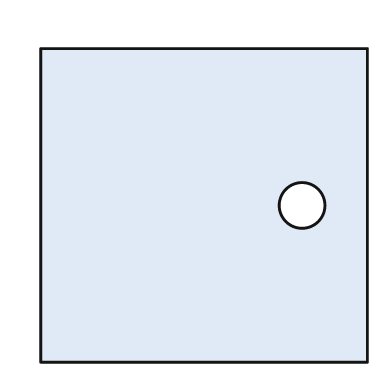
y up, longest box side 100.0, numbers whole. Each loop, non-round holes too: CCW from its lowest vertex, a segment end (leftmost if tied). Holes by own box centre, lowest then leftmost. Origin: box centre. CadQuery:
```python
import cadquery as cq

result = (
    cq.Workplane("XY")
    .moveTo(-50.0, -48.0)
    .lineTo(50.0, -48.0)
    .lineTo(50.0, 48.0)
    .lineTo(-50.0, 48.0)
    .close()
    .moveTo(30.0, 0.0)
    .circle(7.0)
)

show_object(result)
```